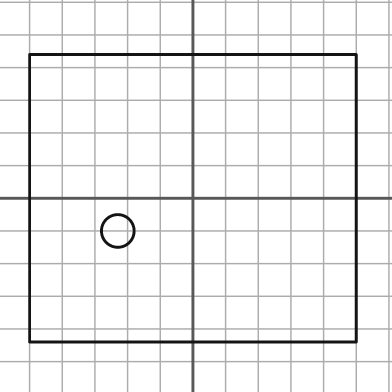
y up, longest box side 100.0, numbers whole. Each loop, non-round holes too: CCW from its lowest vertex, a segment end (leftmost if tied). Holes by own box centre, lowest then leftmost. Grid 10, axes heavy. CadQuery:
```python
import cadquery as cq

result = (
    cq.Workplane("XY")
    .moveTo(-50.0, -44.0)
    .lineTo(50.0, -44.0)
    .lineTo(50.0, 44.0)
    .lineTo(-50.0, 44.0)
    .close()
    .moveTo(-23.0, -10.0)
    .circle(5.0)
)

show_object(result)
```